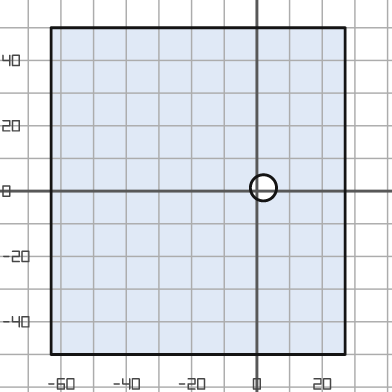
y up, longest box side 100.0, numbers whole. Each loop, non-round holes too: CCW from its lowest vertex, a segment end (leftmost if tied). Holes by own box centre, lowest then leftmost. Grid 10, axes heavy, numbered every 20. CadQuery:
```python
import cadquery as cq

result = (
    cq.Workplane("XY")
    .moveTo(-63.0, -50.0)
    .lineTo(27.0, -50.0)
    .lineTo(27.0, 50.0)
    .lineTo(-63.0, 50.0)
    .close()
    .moveTo(2.0, 1.0)
    .circle(4.0)
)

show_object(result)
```